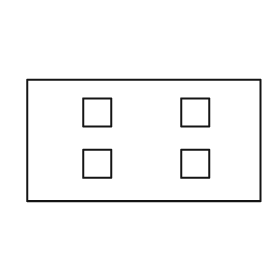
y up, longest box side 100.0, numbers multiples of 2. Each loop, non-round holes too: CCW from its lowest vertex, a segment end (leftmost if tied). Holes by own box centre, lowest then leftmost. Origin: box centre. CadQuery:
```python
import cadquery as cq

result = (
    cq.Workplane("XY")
    .moveTo(-50.0, -26.0)
    .lineTo(50.0, -26.0)
    .lineTo(50.0, 26.0)
    .lineTo(-50.0, 26.0)
    .close()
    .moveTo(-26.0, -16.0)
    .lineTo(-14.0, -16.0)
    .lineTo(-14.0, -4.0)
    .lineTo(-26.0, -4.0)
    .close()
    .moveTo(16.0, -16.0)
    .lineTo(28.0, -16.0)
    .lineTo(28.0, -4.0)
    .lineTo(16.0, -4.0)
    .close()
    .moveTo(-26.0, 6.0)
    .lineTo(-14.0, 6.0)
    .lineTo(-14.0, 18.0)
    .lineTo(-26.0, 18.0)
    .close()
    .moveTo(16.0, 6.0)
    .lineTo(28.0, 6.0)
    .lineTo(28.0, 18.0)
    .lineTo(16.0, 18.0)
    .close()
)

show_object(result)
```